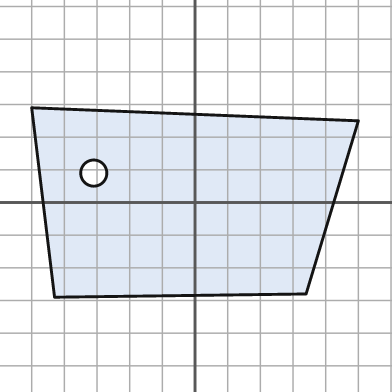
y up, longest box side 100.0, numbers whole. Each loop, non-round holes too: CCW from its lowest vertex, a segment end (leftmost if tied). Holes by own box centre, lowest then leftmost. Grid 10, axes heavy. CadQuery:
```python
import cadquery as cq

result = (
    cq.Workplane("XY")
    .moveTo(-43.0, -29.0)
    .lineTo(34.0, -28.0)
    .lineTo(50.0, 25.0)
    .lineTo(-50.0, 29.0)
    .close()
    .moveTo(-31.0, 9.0)
    .circle(4.0)
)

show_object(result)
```